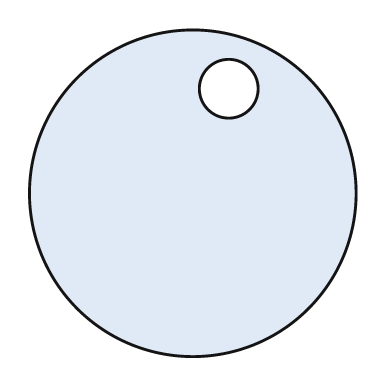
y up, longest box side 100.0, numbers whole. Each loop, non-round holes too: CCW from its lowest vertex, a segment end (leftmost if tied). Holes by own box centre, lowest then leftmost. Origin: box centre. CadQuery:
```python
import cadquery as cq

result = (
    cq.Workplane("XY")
    .moveTo(0.0, 0.0)
    .circle(50.0)
    .moveTo(11.0, 32.0)
    .circle(9.0)
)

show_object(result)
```